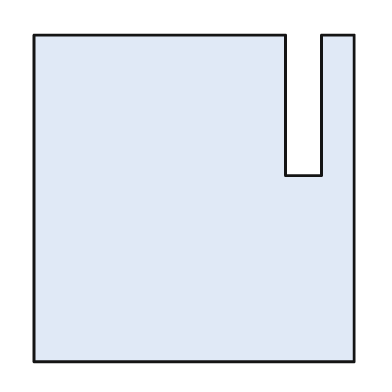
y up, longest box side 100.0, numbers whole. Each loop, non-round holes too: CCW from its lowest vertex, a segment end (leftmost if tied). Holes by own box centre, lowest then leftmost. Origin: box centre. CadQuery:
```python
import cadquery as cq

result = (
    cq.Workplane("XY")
    .moveTo(-49.0, -50.0)
    .lineTo(49.0, -50.0)
    .lineTo(49.0, 50.0)
    .lineTo(39.0, 50.0)
    .lineTo(39.0, 7.0)
    .lineTo(28.0, 7.0)
    .lineTo(28.0, 50.0)
    .lineTo(-49.0, 50.0)
    .close()
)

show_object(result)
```